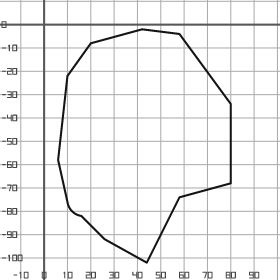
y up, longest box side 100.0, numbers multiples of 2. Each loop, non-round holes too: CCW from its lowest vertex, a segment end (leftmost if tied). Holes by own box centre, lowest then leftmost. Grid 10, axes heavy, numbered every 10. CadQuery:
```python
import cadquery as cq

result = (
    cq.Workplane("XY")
    .moveTo(44.0, -102.0)
    .lineTo(58.0, -74.0)
    .lineTo(80.0, -68.0)
    .lineTo(80.0, -34.0)
    .lineTo(58.0, -4.0)
    .lineTo(42.0, -2.0)
    .lineTo(20.0, -8.0)
    .lineTo(10.0, -22.0)
    .lineTo(6.0, -58.0)
    .lineTo(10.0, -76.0)
    .threePointArc((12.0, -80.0), (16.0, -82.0))
    .lineTo(26.0, -92.0)
    .close()
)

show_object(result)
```